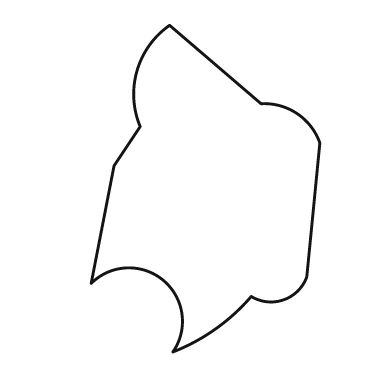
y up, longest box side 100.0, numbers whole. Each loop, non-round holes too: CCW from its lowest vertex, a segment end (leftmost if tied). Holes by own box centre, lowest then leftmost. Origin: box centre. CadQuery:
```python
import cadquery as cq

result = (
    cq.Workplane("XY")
    .moveTo(-10.0, -50.0)
    .threePointArc((3.0, -43.0), (14.0, -33.0))
    .threePointArc((24.0, -34.0), (31.0, -27.0))
    .lineTo(35.0, 14.0)
    .threePointArc((28.0, 23.0), (17.0, 26.0))
    .lineTo(-11.0, 50.0)
    .threePointArc((-21.0, 36.0), (-20.0, 19.0))
    .lineTo(-28.0, 7.0)
    .lineTo(-35.0, -29.0)
    .threePointArc((-13.0, -28.0), (-10.0, -50.0))
    .close()
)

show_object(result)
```